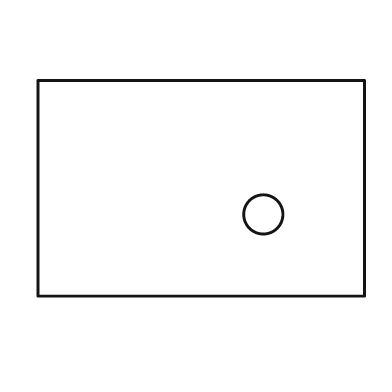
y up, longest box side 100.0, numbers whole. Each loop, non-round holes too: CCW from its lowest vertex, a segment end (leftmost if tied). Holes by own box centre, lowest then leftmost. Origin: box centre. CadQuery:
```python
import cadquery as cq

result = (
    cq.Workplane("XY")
    .moveTo(-50.0, -33.0)
    .lineTo(50.0, -33.0)
    .lineTo(50.0, 33.0)
    .lineTo(-50.0, 33.0)
    .close()
    .moveTo(19.0, -8.0)
    .circle(6.0)
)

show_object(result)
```